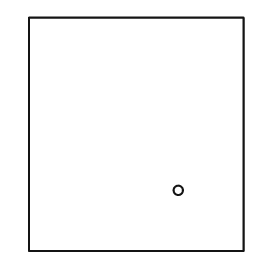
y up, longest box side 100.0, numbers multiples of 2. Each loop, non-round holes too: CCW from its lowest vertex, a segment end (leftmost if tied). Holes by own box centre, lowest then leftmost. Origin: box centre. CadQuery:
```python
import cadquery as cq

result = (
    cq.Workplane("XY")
    .moveTo(-46.0, -50.0)
    .lineTo(46.0, -50.0)
    .lineTo(46.0, 50.0)
    .lineTo(-46.0, 50.0)
    .close()
    .moveTo(18.0, -24.0)
    .circle(2.0)
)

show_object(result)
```